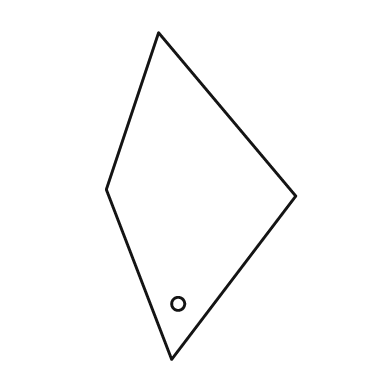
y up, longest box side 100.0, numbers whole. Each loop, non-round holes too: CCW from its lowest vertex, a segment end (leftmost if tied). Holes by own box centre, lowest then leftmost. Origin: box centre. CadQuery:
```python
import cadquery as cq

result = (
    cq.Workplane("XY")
    .moveTo(-9.0, -50.0)
    .lineTo(29.0, 0.0)
    .lineTo(-13.0, 50.0)
    .lineTo(-29.0, 2.0)
    .close()
    .moveTo(-7.0, -33.0)
    .circle(2.0)
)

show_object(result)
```